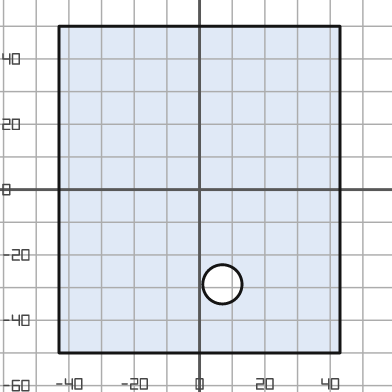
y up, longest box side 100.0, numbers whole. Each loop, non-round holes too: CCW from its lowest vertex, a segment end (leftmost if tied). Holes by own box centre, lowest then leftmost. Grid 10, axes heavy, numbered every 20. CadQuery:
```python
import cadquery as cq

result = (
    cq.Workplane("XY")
    .moveTo(-43.0, -50.0)
    .lineTo(43.0, -50.0)
    .lineTo(43.0, 50.0)
    .lineTo(-43.0, 50.0)
    .close()
    .moveTo(7.0, -29.0)
    .circle(6.0)
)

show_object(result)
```